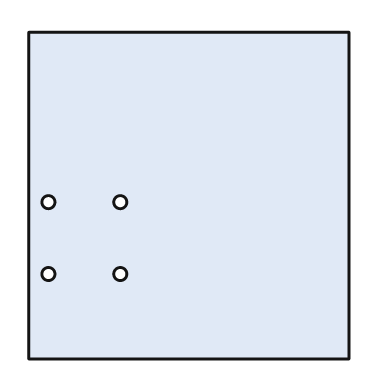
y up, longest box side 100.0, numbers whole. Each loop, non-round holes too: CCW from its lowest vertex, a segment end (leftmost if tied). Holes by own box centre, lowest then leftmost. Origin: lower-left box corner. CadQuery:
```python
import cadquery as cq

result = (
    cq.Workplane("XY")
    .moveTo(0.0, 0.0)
    .lineTo(98.0, 0.0)
    .lineTo(98.0, 100.0)
    .lineTo(0.0, 100.0)
    .close()
    .moveTo(6.0, 26.0)
    .circle(2.0)
    .moveTo(28.0, 26.0)
    .circle(2.0)
    .moveTo(6.0, 48.0)
    .circle(2.0)
    .moveTo(28.0, 48.0)
    .circle(2.0)
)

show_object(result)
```